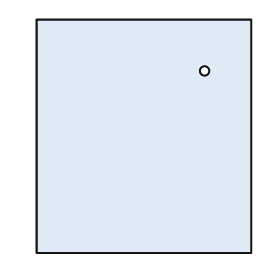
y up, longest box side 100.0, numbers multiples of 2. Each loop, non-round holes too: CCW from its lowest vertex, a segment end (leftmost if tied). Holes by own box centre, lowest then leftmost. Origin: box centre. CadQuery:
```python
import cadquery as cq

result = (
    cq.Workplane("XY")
    .moveTo(-46.0, -50.0)
    .lineTo(46.0, -50.0)
    .lineTo(46.0, 50.0)
    .lineTo(-46.0, 50.0)
    .close()
    .moveTo(26.0, 28.0)
    .circle(2.0)
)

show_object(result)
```